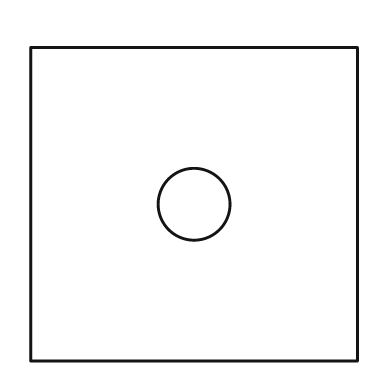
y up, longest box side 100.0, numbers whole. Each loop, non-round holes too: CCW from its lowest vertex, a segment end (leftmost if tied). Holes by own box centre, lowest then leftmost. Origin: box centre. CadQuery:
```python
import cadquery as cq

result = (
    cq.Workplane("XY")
    .moveTo(-50.0, -48.0)
    .lineTo(50.0, -48.0)
    .lineTo(50.0, 48.0)
    .lineTo(-50.0, 48.0)
    .close()
    .moveTo(0.0, 0.0)
    .circle(11.0)
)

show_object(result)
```